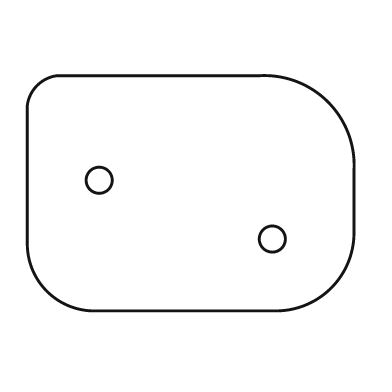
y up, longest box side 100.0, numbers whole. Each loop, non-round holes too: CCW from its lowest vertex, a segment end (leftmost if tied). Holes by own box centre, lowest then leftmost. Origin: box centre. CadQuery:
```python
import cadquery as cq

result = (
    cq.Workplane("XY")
    .moveTo(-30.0, -36.0)
    .lineTo(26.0, -36.0)
    .threePointArc((43.0, -29.0), (50.0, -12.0))
    .lineTo(50.0, 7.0)
    .threePointArc((42.0, 28.0), (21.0, 36.0))
    .lineTo(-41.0, 36.0)
    .threePointArc((-47.0, 33.0), (-50.0, 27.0))
    .lineTo(-50.0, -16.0)
    .threePointArc((-44.0, -30.0), (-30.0, -36.0))
    .close()
    .moveTo(25.0, -14.0)
    .circle(4.0)
    .moveTo(-28.0, 4.0)
    .circle(4.0)
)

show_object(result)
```